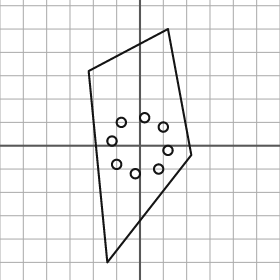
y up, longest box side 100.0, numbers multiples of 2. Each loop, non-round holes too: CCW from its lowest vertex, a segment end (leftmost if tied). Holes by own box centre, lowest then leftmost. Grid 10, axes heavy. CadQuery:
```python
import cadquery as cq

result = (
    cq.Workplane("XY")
    .moveTo(-14.0, -50.0)
    .lineTo(22.0, -4.0)
    .lineTo(12.0, 50.0)
    .lineTo(-22.0, 32.0)
    .close()
    .moveTo(-2.0, -12.0)
    .circle(2.0)
    .moveTo(8.0, -10.0)
    .circle(2.0)
    .moveTo(-10.0, -8.0)
    .circle(2.0)
    .moveTo(12.0, -2.0)
    .circle(2.0)
    .moveTo(-12.0, 2.0)
    .circle(2.0)
    .moveTo(10.0, 8.0)
    .circle(2.0)
    .moveTo(-8.0, 10.0)
    .circle(2.0)
    .moveTo(2.0, 12.0)
    .circle(2.0)
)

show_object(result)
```